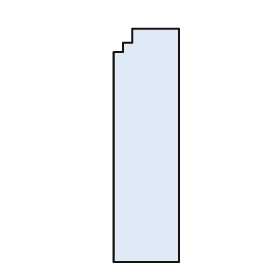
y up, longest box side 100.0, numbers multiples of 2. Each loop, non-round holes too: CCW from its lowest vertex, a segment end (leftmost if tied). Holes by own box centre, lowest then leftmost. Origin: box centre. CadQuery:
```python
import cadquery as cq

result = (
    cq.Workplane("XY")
    .moveTo(-14.0, -50.0)
    .lineTo(14.0, -50.0)
    .lineTo(14.0, 50.0)
    .lineTo(-6.0, 50.0)
    .lineTo(-6.0, 44.0)
    .lineTo(-10.0, 44.0)
    .lineTo(-10.0, 40.0)
    .lineTo(-14.0, 40.0)
    .close()
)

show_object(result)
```